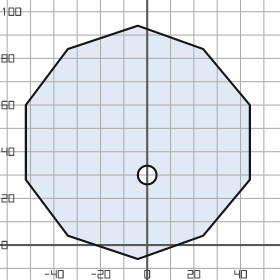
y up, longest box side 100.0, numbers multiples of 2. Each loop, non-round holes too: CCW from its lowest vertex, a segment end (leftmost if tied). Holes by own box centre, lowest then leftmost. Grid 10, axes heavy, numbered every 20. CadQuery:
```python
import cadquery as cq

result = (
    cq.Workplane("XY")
    .moveTo(-4.0, -6.0)
    .lineTo(24.0, 4.0)
    .lineTo(44.0, 28.0)
    .lineTo(44.0, 60.0)
    .lineTo(24.0, 84.0)
    .lineTo(-4.0, 94.0)
    .lineTo(-34.0, 84.0)
    .lineTo(-52.0, 60.0)
    .lineTo(-52.0, 28.0)
    .lineTo(-34.0, 4.0)
    .close()
    .moveTo(0.0, 30.0)
    .circle(4.0)
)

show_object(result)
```